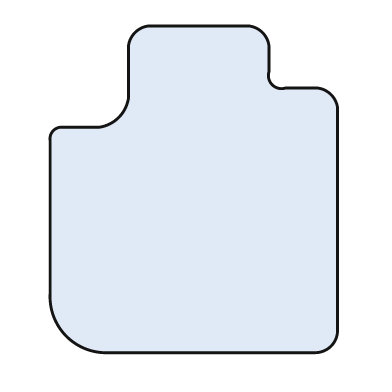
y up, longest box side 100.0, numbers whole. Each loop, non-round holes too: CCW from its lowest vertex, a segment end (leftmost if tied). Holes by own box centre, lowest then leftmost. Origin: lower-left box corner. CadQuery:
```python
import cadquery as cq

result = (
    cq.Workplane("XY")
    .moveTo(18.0, 0.0)
    .lineTo(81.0, 0.0)
    .threePointArc((86.0, 2.0), (88.0, 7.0))
    .lineTo(88.0, 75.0)
    .threePointArc((86.0, 79.0), (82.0, 81.0))
    .lineTo(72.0, 81.0)
    .threePointArc((68.0, 82.0), (67.0, 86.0))
    .lineTo(67.0, 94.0)
    .threePointArc((65.0, 98.0), (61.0, 100.0))
    .lineTo(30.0, 100.0)
    .threePointArc((26.0, 98.0), (24.0, 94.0))
    .lineTo(24.0, 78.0)
    .threePointArc((21.0, 72.0), (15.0, 69.0))
    .lineTo(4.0, 69.0)
    .threePointArc((1.0, 68.0), (0.0, 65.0))
    .lineTo(0.0, 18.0)
    .threePointArc((5.0, 5.0), (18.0, 0.0))
    .close()
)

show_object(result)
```